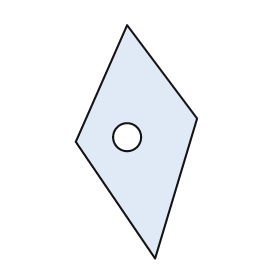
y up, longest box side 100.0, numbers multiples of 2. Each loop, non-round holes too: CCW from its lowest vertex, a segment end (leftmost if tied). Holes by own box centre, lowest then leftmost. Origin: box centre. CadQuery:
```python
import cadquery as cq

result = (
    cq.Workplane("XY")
    .moveTo(8.0, -50.0)
    .lineTo(26.0, 10.0)
    .lineTo(-4.0, 50.0)
    .lineTo(-26.0, 0.0)
    .close()
    .moveTo(-4.0, 2.0)
    .circle(6.0)
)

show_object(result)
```